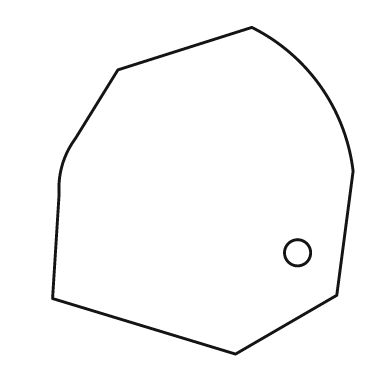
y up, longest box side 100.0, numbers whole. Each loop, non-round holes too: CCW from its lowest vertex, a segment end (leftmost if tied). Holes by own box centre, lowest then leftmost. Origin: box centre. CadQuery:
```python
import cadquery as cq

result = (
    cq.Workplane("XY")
    .moveTo(10.0, -50.0)
    .lineTo(41.0, -32.0)
    .lineTo(46.0, 6.0)
    .threePointArc((36.0, 32.0), (15.0, 50.0))
    .lineTo(-26.0, 37.0)
    .lineTo(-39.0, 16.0)
    .threePointArc((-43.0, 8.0), (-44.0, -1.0))
    .lineTo(-46.0, -33.0)
    .close()
    .moveTo(29.0, -19.0)
    .circle(4.0)
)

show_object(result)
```